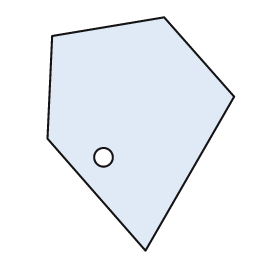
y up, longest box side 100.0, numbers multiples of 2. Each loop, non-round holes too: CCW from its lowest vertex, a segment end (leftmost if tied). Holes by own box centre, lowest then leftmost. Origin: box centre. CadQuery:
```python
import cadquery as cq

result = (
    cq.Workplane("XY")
    .moveTo(2.0, -50.0)
    .lineTo(40.0, 16.0)
    .lineTo(10.0, 50.0)
    .lineTo(-38.0, 42.0)
    .lineTo(-40.0, -2.0)
    .close()
    .moveTo(-16.0, -10.0)
    .circle(4.0)
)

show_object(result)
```